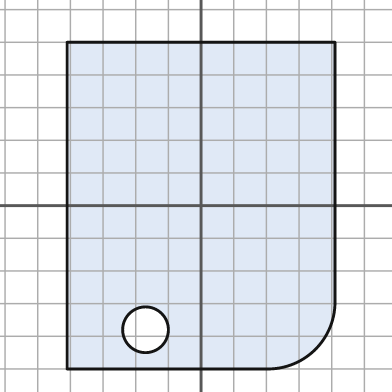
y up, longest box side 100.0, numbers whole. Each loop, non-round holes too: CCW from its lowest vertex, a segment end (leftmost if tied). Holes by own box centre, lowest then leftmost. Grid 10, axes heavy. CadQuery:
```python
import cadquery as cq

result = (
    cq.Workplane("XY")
    .moveTo(-41.0, -50.0)
    .lineTo(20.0, -50.0)
    .threePointArc((35.0, -44.0), (41.0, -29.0))
    .lineTo(41.0, 50.0)
    .lineTo(-41.0, 50.0)
    .close()
    .moveTo(-17.0, -38.0)
    .circle(7.0)
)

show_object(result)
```